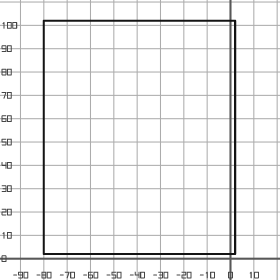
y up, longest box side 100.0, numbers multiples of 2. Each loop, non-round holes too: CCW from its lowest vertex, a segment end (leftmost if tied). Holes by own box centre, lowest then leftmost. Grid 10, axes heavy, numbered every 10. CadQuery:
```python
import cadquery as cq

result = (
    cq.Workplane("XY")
    .moveTo(-80.0, 2.0)
    .lineTo(2.0, 2.0)
    .lineTo(2.0, 102.0)
    .lineTo(-80.0, 102.0)
    .close()
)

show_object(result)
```